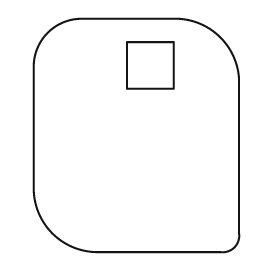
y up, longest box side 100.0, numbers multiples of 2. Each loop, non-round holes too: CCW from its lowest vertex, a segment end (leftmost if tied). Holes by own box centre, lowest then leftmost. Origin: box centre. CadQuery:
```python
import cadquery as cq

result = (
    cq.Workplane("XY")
    .moveTo(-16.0, -50.0)
    .lineTo(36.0, -50.0)
    .threePointArc((42.0, -48.0), (44.0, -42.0))
    .lineTo(44.0, 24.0)
    .threePointArc((36.0, 42.0), (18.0, 50.0))
    .lineTo(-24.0, 50.0)
    .threePointArc((-38.0, 44.0), (-44.0, 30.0))
    .lineTo(-44.0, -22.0)
    .threePointArc((-36.0, -42.0), (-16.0, -50.0))
    .close()
    .moveTo(-4.0, 20.0)
    .lineTo(16.0, 20.0)
    .lineTo(16.0, 40.0)
    .lineTo(-4.0, 40.0)
    .close()
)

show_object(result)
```